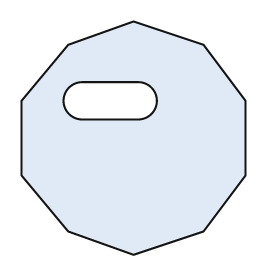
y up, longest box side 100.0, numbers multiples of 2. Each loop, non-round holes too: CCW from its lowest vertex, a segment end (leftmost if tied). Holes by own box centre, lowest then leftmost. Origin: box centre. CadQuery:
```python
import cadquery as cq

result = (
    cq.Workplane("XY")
    .moveTo(0.0, -50.0)
    .lineTo(30.0, -40.0)
    .lineTo(48.0, -16.0)
    .lineTo(48.0, 16.0)
    .lineTo(30.0, 40.0)
    .lineTo(0.0, 50.0)
    .lineTo(-28.0, 40.0)
    .lineTo(-48.0, 16.0)
    .lineTo(-48.0, -16.0)
    .lineTo(-28.0, -40.0)
    .close()
    .moveTo(-22.0, 8.0)
    .lineTo(2.0, 8.0)
    .threePointArc((10.0, 16.0), (2.0, 24.0))
    .lineTo(-22.0, 24.0)
    .threePointArc((-30.0, 16.0), (-22.0, 8.0))
    .close()
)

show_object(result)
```